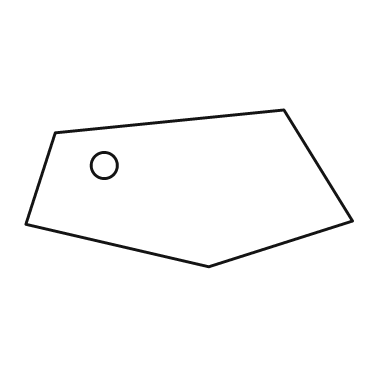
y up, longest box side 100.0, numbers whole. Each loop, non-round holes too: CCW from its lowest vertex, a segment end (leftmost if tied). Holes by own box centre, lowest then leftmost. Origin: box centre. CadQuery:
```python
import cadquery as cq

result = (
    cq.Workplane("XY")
    .moveTo(6.0, -24.0)
    .lineTo(50.0, -10.0)
    .lineTo(29.0, 24.0)
    .lineTo(-41.0, 17.0)
    .lineTo(-50.0, -11.0)
    .close()
    .moveTo(-26.0, 7.0)
    .circle(4.0)
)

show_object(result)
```